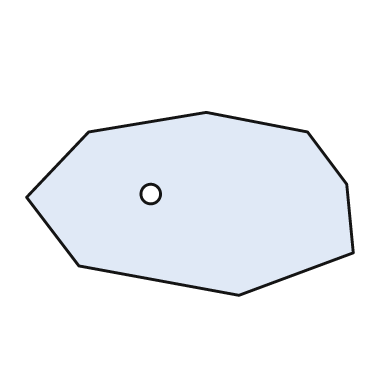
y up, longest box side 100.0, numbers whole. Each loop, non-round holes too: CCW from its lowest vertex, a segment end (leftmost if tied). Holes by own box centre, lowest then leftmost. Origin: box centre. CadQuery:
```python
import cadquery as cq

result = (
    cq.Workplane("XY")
    .moveTo(15.0, -28.0)
    .lineTo(50.0, -15.0)
    .lineTo(48.0, 6.0)
    .lineTo(36.0, 22.0)
    .lineTo(5.0, 28.0)
    .lineTo(-31.0, 22.0)
    .lineTo(-50.0, 2.0)
    .lineTo(-34.0, -19.0)
    .close()
    .moveTo(-12.0, 3.0)
    .circle(3.0)
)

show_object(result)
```